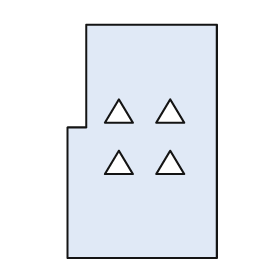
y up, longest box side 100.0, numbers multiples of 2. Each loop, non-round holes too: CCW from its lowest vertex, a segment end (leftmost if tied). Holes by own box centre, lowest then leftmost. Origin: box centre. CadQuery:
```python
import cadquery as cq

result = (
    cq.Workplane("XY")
    .moveTo(-32.0, -50.0)
    .lineTo(32.0, -50.0)
    .lineTo(32.0, 50.0)
    .lineTo(-24.0, 50.0)
    .lineTo(-24.0, 6.0)
    .lineTo(-32.0, 6.0)
    .close()
    .moveTo(-16.0, -14.0)
    .lineTo(-4.0, -14.0)
    .lineTo(-10.0, -4.0)
    .close()
    .moveTo(6.0, -14.0)
    .lineTo(18.0, -14.0)
    .lineTo(12.0, -4.0)
    .close()
    .moveTo(-16.0, 8.0)
    .lineTo(-4.0, 8.0)
    .lineTo(-10.0, 18.0)
    .close()
    .moveTo(6.0, 8.0)
    .lineTo(18.0, 8.0)
    .lineTo(12.0, 18.0)
    .close()
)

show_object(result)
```